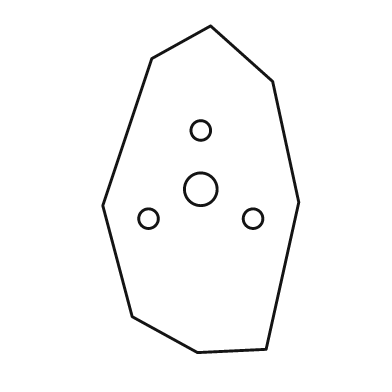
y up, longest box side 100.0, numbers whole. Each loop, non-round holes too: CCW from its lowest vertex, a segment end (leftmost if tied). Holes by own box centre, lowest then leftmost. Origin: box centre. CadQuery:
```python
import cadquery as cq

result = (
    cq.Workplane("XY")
    .moveTo(-1.0, -50.0)
    .lineTo(20.0, -49.0)
    .lineTo(30.0, -4.0)
    .lineTo(22.0, 33.0)
    .lineTo(3.0, 50.0)
    .lineTo(-15.0, 40.0)
    .lineTo(-30.0, -5.0)
    .lineTo(-21.0, -39.0)
    .close()
    .moveTo(-16.0, -9.0)
    .circle(3.0)
    .moveTo(16.0, -9.0)
    .circle(3.0)
    .moveTo(0.0, 0.0)
    .circle(5.0)
    .moveTo(0.0, 18.0)
    .circle(3.0)
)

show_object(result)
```